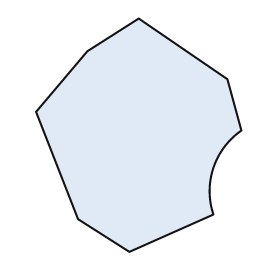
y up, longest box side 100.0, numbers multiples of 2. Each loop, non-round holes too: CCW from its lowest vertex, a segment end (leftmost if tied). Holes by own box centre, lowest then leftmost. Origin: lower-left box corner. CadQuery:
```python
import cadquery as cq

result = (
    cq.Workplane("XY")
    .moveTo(40.0, 0.0)
    .lineTo(76.0, 16.0)
    .threePointArc((76.0, 36.0), (88.0, 52.0))
    .lineTo(82.0, 74.0)
    .lineTo(44.0, 100.0)
    .lineTo(22.0, 86.0)
    .lineTo(0.0, 60.0)
    .lineTo(18.0, 14.0)
    .close()
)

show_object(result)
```